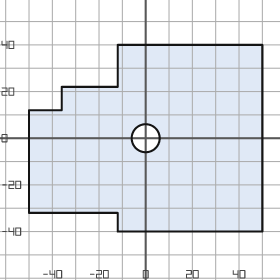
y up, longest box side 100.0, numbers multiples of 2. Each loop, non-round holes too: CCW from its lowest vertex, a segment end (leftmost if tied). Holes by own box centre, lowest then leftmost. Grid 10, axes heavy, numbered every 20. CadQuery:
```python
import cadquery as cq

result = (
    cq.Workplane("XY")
    .moveTo(-12.0, -40.0)
    .lineTo(50.0, -40.0)
    .lineTo(50.0, 40.0)
    .lineTo(-12.0, 40.0)
    .lineTo(-12.0, 22.0)
    .lineTo(-36.0, 22.0)
    .lineTo(-36.0, 12.0)
    .lineTo(-50.0, 12.0)
    .lineTo(-50.0, -32.0)
    .lineTo(-12.0, -32.0)
    .close()
    .moveTo(0.0, 0.0)
    .circle(6.0)
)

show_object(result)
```